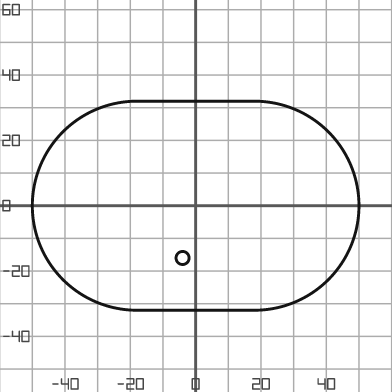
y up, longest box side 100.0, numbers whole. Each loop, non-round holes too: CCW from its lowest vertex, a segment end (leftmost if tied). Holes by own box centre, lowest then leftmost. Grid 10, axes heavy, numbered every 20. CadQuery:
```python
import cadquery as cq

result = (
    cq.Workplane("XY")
    .moveTo(-18.0, -32.0)
    .lineTo(18.0, -32.0)
    .threePointArc((50.0, 0.0), (18.0, 32.0))
    .lineTo(-18.0, 32.0)
    .threePointArc((-50.0, 0.0), (-18.0, -32.0))
    .close()
    .moveTo(-4.0, -16.0)
    .circle(2.0)
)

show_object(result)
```